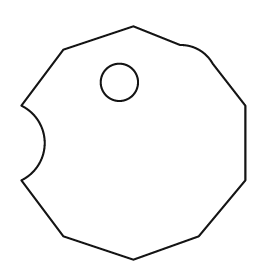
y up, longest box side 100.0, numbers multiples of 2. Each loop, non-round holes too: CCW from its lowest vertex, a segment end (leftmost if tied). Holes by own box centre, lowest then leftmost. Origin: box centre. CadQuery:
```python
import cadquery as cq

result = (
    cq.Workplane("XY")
    .moveTo(0.0, -50.0)
    .lineTo(28.0, -40.0)
    .lineTo(48.0, -16.0)
    .lineTo(48.0, 16.0)
    .lineTo(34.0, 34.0)
    .threePointArc((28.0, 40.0), (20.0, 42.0))
    .lineTo(0.0, 50.0)
    .lineTo(-30.0, 40.0)
    .lineTo(-48.0, 16.0)
    .threePointArc((-38.0, 0.0), (-48.0, -16.0))
    .lineTo(-30.0, -40.0)
    .close()
    .moveTo(-6.0, 26.0)
    .circle(8.0)
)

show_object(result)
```